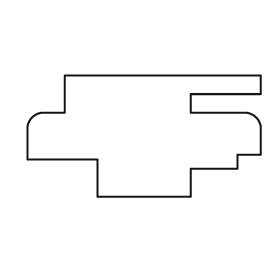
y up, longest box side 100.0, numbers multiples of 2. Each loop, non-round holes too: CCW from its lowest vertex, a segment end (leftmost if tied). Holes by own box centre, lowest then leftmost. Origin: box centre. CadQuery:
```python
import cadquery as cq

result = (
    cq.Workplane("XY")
    .moveTo(-20.0, -26.0)
    .lineTo(20.0, -26.0)
    .lineTo(20.0, -14.0)
    .lineTo(40.0, -14.0)
    .lineTo(40.0, -8.0)
    .lineTo(50.0, -8.0)
    .lineTo(50.0, 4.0)
    .threePointArc((48.0, 8.0), (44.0, 10.0))
    .lineTo(20.0, 10.0)
    .lineTo(20.0, 18.0)
    .lineTo(50.0, 18.0)
    .lineTo(50.0, 26.0)
    .lineTo(-34.0, 26.0)
    .lineTo(-34.0, 10.0)
    .lineTo(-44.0, 10.0)
    .threePointArc((-48.0, 8.0), (-50.0, 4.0))
    .lineTo(-50.0, -10.0)
    .lineTo(-20.0, -10.0)
    .close()
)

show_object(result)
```